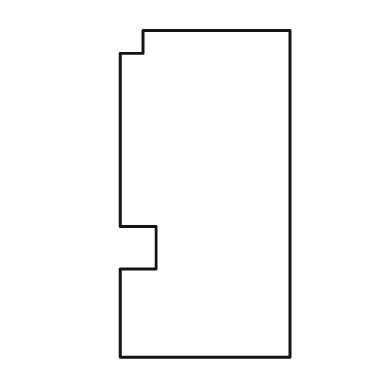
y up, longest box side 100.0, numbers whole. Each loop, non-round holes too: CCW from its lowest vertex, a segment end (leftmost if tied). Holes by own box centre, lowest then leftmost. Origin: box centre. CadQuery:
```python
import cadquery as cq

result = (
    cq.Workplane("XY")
    .moveTo(-26.0, -50.0)
    .lineTo(26.0, -50.0)
    .lineTo(26.0, 50.0)
    .lineTo(-19.0, 50.0)
    .lineTo(-19.0, 43.0)
    .lineTo(-26.0, 43.0)
    .lineTo(-26.0, -10.0)
    .lineTo(-15.0, -10.0)
    .lineTo(-15.0, -23.0)
    .lineTo(-26.0, -23.0)
    .close()
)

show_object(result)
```